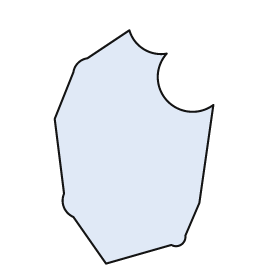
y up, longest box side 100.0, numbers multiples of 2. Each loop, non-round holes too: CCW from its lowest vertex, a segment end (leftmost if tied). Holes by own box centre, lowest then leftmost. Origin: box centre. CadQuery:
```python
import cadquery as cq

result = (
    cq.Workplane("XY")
    .moveTo(-12.0, -50.0)
    .lineTo(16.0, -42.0)
    .threePointArc((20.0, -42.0), (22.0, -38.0))
    .lineTo(28.0, -24.0)
    .lineTo(34.0, 18.0)
    .threePointArc((14.0, 20.0), (14.0, 40.0))
    .threePointArc((4.0, 42.0), (-2.0, 50.0))
    .lineTo(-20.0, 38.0)
    .threePointArc((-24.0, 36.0), (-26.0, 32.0))
    .lineTo(-34.0, 12.0)
    .lineTo(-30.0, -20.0)
    .threePointArc((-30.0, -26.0), (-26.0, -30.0))
    .close()
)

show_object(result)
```